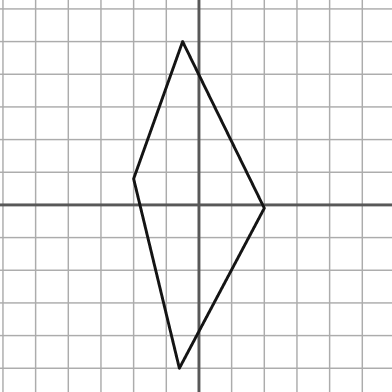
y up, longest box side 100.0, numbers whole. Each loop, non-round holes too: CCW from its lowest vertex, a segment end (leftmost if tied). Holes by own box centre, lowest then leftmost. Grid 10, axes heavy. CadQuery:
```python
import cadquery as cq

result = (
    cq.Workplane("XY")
    .moveTo(-6.0, -50.0)
    .lineTo(20.0, -1.0)
    .lineTo(-5.0, 50.0)
    .lineTo(-20.0, 8.0)
    .close()
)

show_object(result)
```